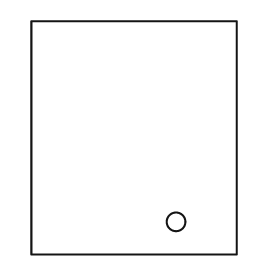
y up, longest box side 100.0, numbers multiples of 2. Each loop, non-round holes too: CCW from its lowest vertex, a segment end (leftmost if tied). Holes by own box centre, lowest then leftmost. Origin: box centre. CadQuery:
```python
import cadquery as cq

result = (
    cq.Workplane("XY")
    .moveTo(-44.0, -50.0)
    .lineTo(44.0, -50.0)
    .lineTo(44.0, 50.0)
    .lineTo(-44.0, 50.0)
    .close()
    .moveTo(18.0, -36.0)
    .circle(4.0)
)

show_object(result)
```